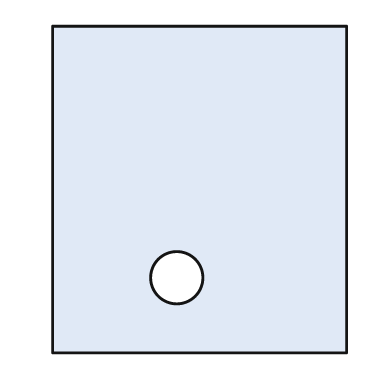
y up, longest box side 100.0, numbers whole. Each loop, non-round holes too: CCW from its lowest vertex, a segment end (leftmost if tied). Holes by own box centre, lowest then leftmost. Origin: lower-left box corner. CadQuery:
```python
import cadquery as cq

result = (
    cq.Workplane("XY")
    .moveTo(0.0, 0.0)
    .lineTo(90.0, 0.0)
    .lineTo(90.0, 100.0)
    .lineTo(0.0, 100.0)
    .close()
    .moveTo(38.0, 23.0)
    .circle(8.0)
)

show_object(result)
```